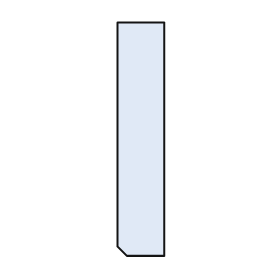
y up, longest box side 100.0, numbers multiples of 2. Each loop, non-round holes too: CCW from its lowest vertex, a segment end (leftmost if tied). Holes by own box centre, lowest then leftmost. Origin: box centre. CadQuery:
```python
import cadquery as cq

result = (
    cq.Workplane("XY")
    .moveTo(-6.0, -50.0)
    .lineTo(10.0, -50.0)
    .lineTo(10.0, 50.0)
    .lineTo(-10.0, 50.0)
    .lineTo(-10.0, -46.0)
    .close()
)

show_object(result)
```